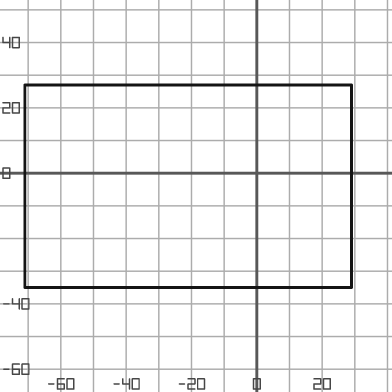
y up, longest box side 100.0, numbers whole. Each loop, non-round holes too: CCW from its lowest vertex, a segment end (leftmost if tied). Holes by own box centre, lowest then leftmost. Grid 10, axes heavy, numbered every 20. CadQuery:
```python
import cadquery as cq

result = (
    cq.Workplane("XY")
    .moveTo(-71.0, -35.0)
    .lineTo(29.0, -35.0)
    .lineTo(29.0, 27.0)
    .lineTo(-71.0, 27.0)
    .close()
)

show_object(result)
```